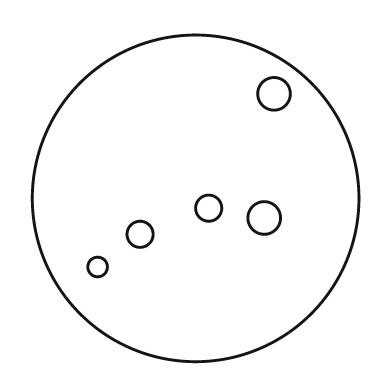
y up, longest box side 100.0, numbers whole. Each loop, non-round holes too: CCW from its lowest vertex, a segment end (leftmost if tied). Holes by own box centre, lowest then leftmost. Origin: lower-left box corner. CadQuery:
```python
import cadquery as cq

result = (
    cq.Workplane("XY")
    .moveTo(50.0, 50.0)
    .circle(50.0)
    .moveTo(20.0, 29.0)
    .circle(3.0)
    .moveTo(33.0, 39.0)
    .circle(4.0)
    .moveTo(71.0, 44.0)
    .circle(5.0)
    .moveTo(54.0, 47.0)
    .circle(4.0)
    .moveTo(74.0, 82.0)
    .circle(5.0)
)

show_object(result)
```